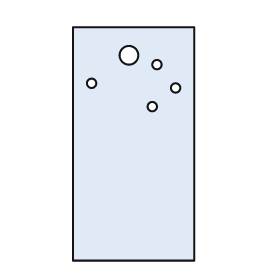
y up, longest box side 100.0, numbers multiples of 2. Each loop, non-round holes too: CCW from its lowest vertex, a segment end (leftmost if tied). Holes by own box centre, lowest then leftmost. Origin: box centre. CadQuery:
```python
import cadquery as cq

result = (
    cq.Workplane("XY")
    .moveTo(-26.0, -50.0)
    .lineTo(26.0, -50.0)
    .lineTo(26.0, 50.0)
    .lineTo(-26.0, 50.0)
    .close()
    .moveTo(8.0, 16.0)
    .circle(2.0)
    .moveTo(18.0, 24.0)
    .circle(2.0)
    .moveTo(-18.0, 26.0)
    .circle(2.0)
    .moveTo(10.0, 34.0)
    .circle(2.0)
    .moveTo(-2.0, 38.0)
    .circle(4.0)
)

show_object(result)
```